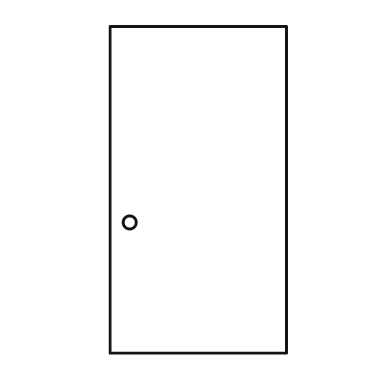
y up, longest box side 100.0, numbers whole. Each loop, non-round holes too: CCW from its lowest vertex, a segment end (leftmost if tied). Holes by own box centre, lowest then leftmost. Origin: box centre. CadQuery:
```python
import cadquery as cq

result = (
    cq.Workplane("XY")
    .moveTo(-27.0, -50.0)
    .lineTo(27.0, -50.0)
    .lineTo(27.0, 50.0)
    .lineTo(-27.0, 50.0)
    .close()
    .moveTo(-21.0, -10.0)
    .circle(2.0)
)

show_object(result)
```